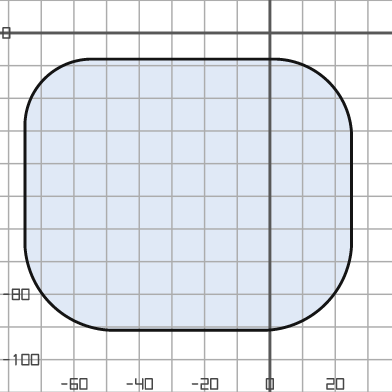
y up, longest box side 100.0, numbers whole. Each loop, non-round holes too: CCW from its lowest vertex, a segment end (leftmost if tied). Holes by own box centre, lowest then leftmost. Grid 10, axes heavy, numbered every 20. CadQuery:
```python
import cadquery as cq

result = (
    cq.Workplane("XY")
    .moveTo(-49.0, -91.0)
    .lineTo(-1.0, -91.0)
    .threePointArc((17.0, -83.0), (25.0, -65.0))
    .lineTo(25.0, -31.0)
    .threePointArc((18.0, -15.0), (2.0, -8.0))
    .lineTo(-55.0, -8.0)
    .threePointArc((-69.0, -14.0), (-75.0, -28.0))
    .lineTo(-75.0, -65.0)
    .threePointArc((-67.0, -83.0), (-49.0, -91.0))
    .close()
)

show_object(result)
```